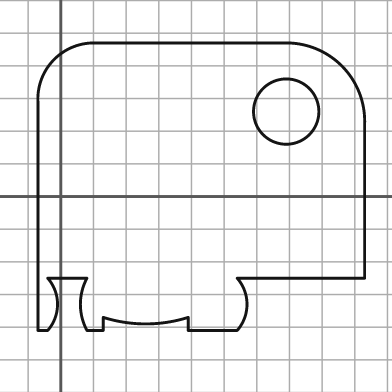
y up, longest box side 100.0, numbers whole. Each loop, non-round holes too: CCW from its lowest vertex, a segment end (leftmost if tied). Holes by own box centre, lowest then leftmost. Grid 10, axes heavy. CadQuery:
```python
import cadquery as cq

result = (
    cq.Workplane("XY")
    .moveTo(-7.0, -41.0)
    .lineTo(-4.0, -41.0)
    .threePointArc((-1.0, -33.0), (-4.0, -25.0))
    .lineTo(8.0, -25.0)
    .threePointArc((6.0, -33.0), (8.0, -41.0))
    .lineTo(13.0, -41.0)
    .lineTo(13.0, -37.0)
    .threePointArc((26.0, -39.0), (39.0, -37.0))
    .lineTo(39.0, -41.0)
    .lineTo(54.0, -41.0)
    .threePointArc((57.0, -33.0), (54.0, -25.0))
    .lineTo(93.0, -25.0)
    .lineTo(93.0, 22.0)
    .threePointArc((86.0, 40.0), (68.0, 47.0))
    .lineTo(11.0, 47.0)
    .threePointArc((-2.0, 42.0), (-7.0, 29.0))
    .close()
    .moveTo(69.0, 26.0)
    .circle(10.0)
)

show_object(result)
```